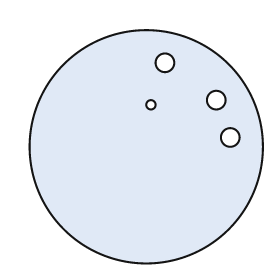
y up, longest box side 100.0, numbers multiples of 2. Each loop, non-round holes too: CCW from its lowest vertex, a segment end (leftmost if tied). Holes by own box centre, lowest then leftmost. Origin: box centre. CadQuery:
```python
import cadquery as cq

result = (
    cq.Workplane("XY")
    .moveTo(0.0, 0.0)
    .circle(50.0)
    .moveTo(36.0, 4.0)
    .circle(4.0)
    .moveTo(2.0, 18.0)
    .circle(2.0)
    .moveTo(30.0, 20.0)
    .circle(4.0)
    .moveTo(8.0, 36.0)
    .circle(4.0)
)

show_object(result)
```